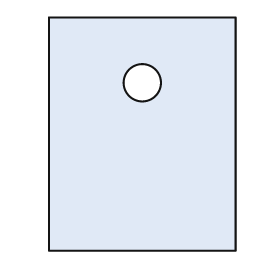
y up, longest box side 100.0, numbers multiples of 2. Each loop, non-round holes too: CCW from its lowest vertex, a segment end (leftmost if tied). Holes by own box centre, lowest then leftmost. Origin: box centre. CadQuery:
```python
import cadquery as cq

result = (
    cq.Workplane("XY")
    .moveTo(-40.0, -50.0)
    .lineTo(40.0, -50.0)
    .lineTo(40.0, 50.0)
    .lineTo(-40.0, 50.0)
    .close()
    .moveTo(0.0, 22.0)
    .circle(8.0)
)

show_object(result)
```